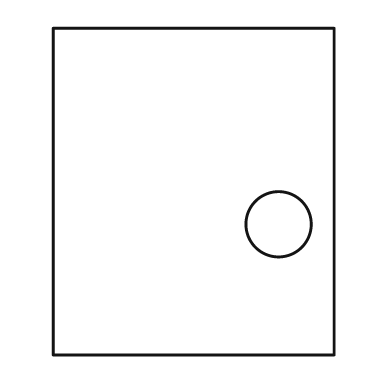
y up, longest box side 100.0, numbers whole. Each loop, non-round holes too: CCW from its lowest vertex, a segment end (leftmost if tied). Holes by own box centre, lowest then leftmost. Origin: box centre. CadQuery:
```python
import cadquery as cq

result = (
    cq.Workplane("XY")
    .moveTo(-43.0, -50.0)
    .lineTo(43.0, -50.0)
    .lineTo(43.0, 50.0)
    .lineTo(-43.0, 50.0)
    .close()
    .moveTo(26.0, -10.0)
    .circle(10.0)
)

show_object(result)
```